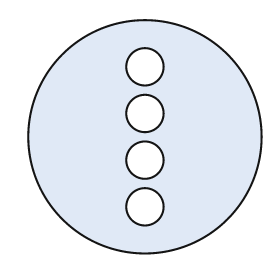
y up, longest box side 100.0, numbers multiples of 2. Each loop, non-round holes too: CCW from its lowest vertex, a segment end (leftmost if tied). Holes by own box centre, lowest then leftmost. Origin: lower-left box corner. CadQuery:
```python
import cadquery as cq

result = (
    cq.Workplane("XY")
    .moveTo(50.0, 50.0)
    .circle(50.0)
    .moveTo(50.0, 20.0)
    .circle(8.0)
    .moveTo(50.0, 40.0)
    .circle(8.0)
    .moveTo(50.0, 60.0)
    .circle(8.0)
    .moveTo(50.0, 80.0)
    .circle(8.0)
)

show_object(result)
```